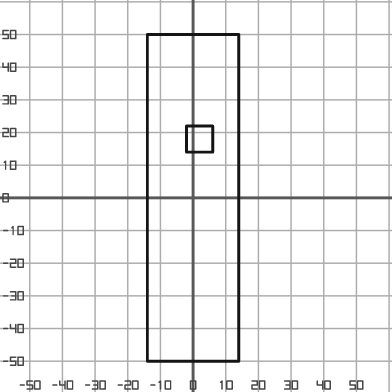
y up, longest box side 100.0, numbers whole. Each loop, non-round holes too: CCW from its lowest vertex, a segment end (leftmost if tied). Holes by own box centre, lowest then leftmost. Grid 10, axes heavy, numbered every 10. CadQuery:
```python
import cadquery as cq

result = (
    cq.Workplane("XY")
    .moveTo(-14.0, -50.0)
    .lineTo(14.0, -50.0)
    .lineTo(14.0, 50.0)
    .lineTo(-14.0, 50.0)
    .close()
    .moveTo(-2.0, 14.0)
    .lineTo(6.0, 14.0)
    .lineTo(6.0, 22.0)
    .lineTo(-2.0, 22.0)
    .close()
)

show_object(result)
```